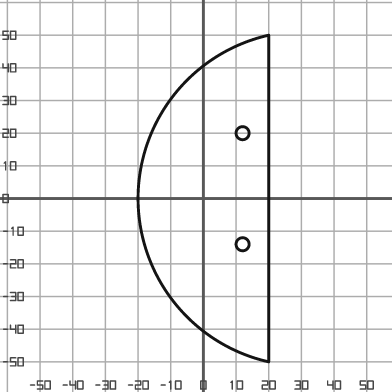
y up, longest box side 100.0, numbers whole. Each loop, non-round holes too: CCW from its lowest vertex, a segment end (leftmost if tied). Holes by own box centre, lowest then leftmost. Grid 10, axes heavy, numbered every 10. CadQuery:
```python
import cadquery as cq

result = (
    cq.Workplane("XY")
    .moveTo(20.0, -50.0)
    .lineTo(20.0, 50.0)
    .threePointArc((-20.0, 0.0), (20.0, -50.0))
    .close()
    .moveTo(12.0, -14.0)
    .circle(2.0)
    .moveTo(12.0, 20.0)
    .circle(2.0)
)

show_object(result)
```